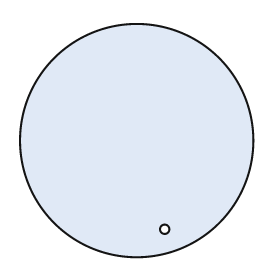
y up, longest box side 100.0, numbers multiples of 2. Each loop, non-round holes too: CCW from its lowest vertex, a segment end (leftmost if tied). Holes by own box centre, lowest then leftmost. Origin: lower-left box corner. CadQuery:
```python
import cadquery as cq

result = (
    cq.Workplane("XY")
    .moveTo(50.0, 50.0)
    .circle(50.0)
    .moveTo(62.0, 12.0)
    .circle(2.0)
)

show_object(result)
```